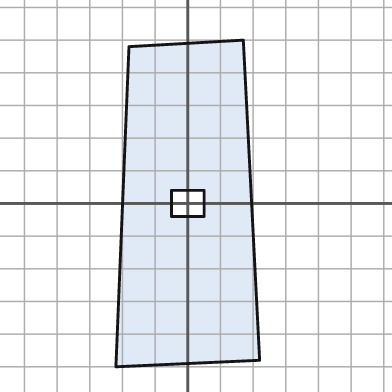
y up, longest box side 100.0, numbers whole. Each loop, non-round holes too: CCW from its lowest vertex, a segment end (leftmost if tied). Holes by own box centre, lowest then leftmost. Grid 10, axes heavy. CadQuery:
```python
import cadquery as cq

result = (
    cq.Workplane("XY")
    .moveTo(-22.0, -50.0)
    .lineTo(22.0, -48.0)
    .lineTo(17.0, 50.0)
    .lineTo(-18.0, 48.0)
    .close()
    .moveTo(-5.0, -4.0)
    .lineTo(5.0, -4.0)
    .lineTo(5.0, 4.0)
    .lineTo(-5.0, 4.0)
    .close()
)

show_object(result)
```